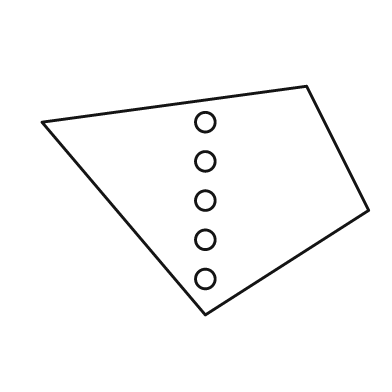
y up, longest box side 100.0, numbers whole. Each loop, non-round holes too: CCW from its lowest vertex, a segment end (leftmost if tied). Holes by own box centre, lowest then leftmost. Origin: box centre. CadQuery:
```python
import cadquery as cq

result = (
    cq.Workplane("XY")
    .moveTo(0.0, -35.0)
    .lineTo(50.0, -3.0)
    .lineTo(31.0, 35.0)
    .lineTo(-50.0, 24.0)
    .close()
    .moveTo(0.0, -24.0)
    .circle(3.0)
    .moveTo(0.0, -12.0)
    .circle(3.0)
    .moveTo(0.0, 0.0)
    .circle(3.0)
    .moveTo(0.0, 12.0)
    .circle(3.0)
    .moveTo(0.0, 24.0)
    .circle(3.0)
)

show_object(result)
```